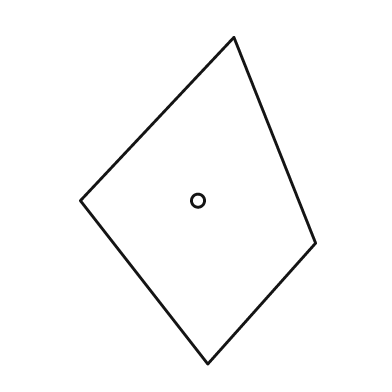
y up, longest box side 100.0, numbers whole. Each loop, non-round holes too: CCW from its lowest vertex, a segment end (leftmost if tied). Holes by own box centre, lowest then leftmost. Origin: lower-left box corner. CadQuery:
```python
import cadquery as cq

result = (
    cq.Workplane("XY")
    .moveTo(39.0, 0.0)
    .lineTo(72.0, 37.0)
    .lineTo(47.0, 100.0)
    .lineTo(0.0, 50.0)
    .close()
    .moveTo(36.0, 50.0)
    .circle(2.0)
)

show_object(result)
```